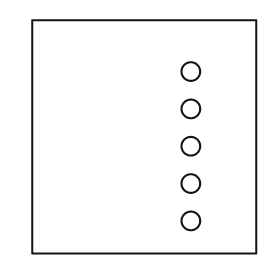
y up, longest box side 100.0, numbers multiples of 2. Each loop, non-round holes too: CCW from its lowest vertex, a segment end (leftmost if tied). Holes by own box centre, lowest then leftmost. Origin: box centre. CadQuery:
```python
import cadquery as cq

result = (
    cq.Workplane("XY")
    .moveTo(-48.0, -50.0)
    .lineTo(48.0, -50.0)
    .lineTo(48.0, 50.0)
    .lineTo(-48.0, 50.0)
    .close()
    .moveTo(20.0, -36.0)
    .circle(4.0)
    .moveTo(20.0, -20.0)
    .circle(4.0)
    .moveTo(20.0, -4.0)
    .circle(4.0)
    .moveTo(20.0, 12.0)
    .circle(4.0)
    .moveTo(20.0, 28.0)
    .circle(4.0)
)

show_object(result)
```